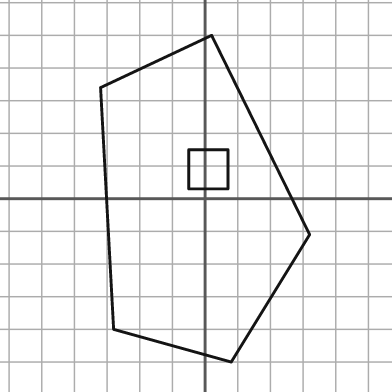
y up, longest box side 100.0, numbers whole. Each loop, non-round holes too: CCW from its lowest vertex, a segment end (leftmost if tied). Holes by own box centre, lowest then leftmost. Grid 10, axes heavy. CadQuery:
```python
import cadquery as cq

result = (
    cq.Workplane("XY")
    .moveTo(8.0, -50.0)
    .lineTo(32.0, -11.0)
    .lineTo(2.0, 50.0)
    .lineTo(-32.0, 34.0)
    .lineTo(-28.0, -40.0)
    .close()
    .moveTo(-5.0, 3.0)
    .lineTo(7.0, 3.0)
    .lineTo(7.0, 15.0)
    .lineTo(-5.0, 15.0)
    .close()
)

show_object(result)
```